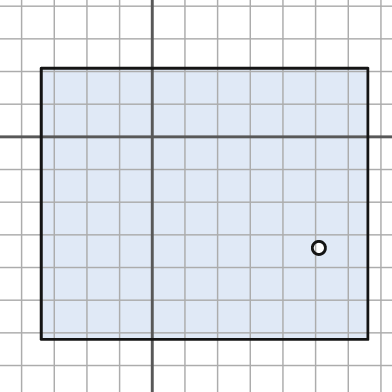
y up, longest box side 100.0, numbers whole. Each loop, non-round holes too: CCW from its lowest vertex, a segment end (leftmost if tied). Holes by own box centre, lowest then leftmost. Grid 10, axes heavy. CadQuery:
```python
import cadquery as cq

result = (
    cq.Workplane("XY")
    .moveTo(-34.0, -62.0)
    .lineTo(66.0, -62.0)
    .lineTo(66.0, 21.0)
    .lineTo(-34.0, 21.0)
    .close()
    .moveTo(51.0, -34.0)
    .circle(2.0)
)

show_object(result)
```